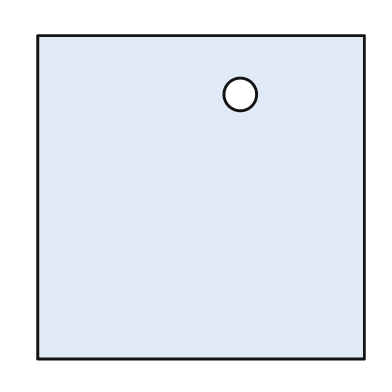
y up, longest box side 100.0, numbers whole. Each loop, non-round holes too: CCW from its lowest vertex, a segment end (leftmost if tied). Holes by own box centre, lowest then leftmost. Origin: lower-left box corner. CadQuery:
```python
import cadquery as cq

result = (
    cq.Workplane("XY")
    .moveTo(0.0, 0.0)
    .lineTo(100.0, 0.0)
    .lineTo(100.0, 99.0)
    .lineTo(0.0, 99.0)
    .close()
    .moveTo(62.0, 81.0)
    .circle(5.0)
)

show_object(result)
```